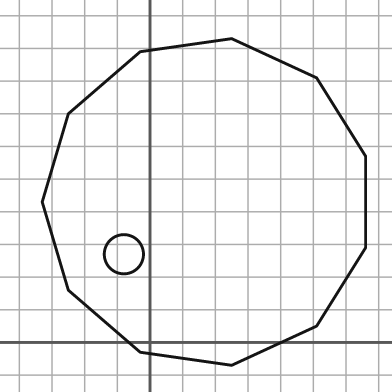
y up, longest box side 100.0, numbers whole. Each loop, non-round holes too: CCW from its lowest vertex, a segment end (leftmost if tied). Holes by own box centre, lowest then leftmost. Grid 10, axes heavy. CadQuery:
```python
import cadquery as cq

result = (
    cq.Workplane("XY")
    .moveTo(25.0, -7.0)
    .lineTo(51.0, 5.0)
    .lineTo(66.0, 29.0)
    .lineTo(66.0, 57.0)
    .lineTo(51.0, 81.0)
    .lineTo(25.0, 93.0)
    .lineTo(-3.0, 89.0)
    .lineTo(-25.0, 70.0)
    .lineTo(-33.0, 43.0)
    .lineTo(-25.0, 16.0)
    .lineTo(-3.0, -3.0)
    .close()
    .moveTo(-8.0, 27.0)
    .circle(6.0)
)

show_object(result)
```